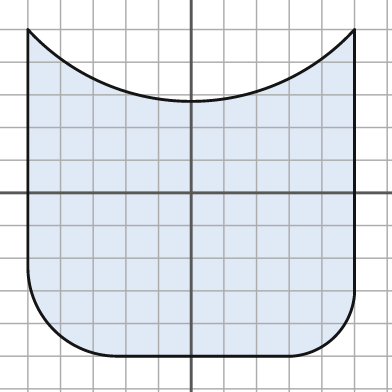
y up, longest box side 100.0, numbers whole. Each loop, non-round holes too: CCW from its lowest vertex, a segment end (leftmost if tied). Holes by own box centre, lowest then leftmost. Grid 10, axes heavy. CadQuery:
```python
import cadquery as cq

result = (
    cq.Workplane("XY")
    .moveTo(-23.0, -50.0)
    .lineTo(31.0, -50.0)
    .threePointArc((44.0, -44.0), (50.0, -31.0))
    .lineTo(50.0, 50.0)
    .threePointArc((0.0, 28.0), (-50.0, 50.0))
    .lineTo(-50.0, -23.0)
    .threePointArc((-42.0, -42.0), (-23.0, -50.0))
    .close()
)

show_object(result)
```